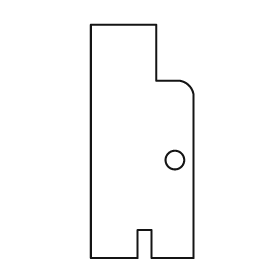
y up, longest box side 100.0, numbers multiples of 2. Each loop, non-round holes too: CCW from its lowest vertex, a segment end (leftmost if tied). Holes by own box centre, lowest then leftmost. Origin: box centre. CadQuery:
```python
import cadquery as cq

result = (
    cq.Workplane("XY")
    .moveTo(-22.0, -50.0)
    .lineTo(-2.0, -50.0)
    .lineTo(-2.0, -38.0)
    .lineTo(4.0, -38.0)
    .lineTo(4.0, -50.0)
    .lineTo(22.0, -50.0)
    .lineTo(22.0, 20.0)
    .threePointArc((20.0, 24.0), (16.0, 26.0))
    .lineTo(6.0, 26.0)
    .lineTo(6.0, 50.0)
    .lineTo(-22.0, 50.0)
    .close()
    .moveTo(14.0, -8.0)
    .circle(4.0)
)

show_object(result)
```